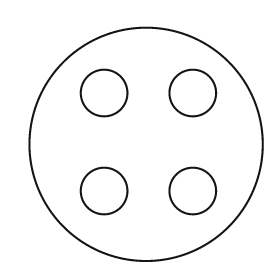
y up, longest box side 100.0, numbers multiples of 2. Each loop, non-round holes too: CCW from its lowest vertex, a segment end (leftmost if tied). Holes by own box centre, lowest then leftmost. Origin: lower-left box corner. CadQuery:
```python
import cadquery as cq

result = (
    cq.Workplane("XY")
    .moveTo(50.0, 50.0)
    .circle(50.0)
    .moveTo(32.0, 30.0)
    .circle(10.0)
    .moveTo(70.0, 30.0)
    .circle(10.0)
    .moveTo(32.0, 72.0)
    .circle(10.0)
    .moveTo(70.0, 72.0)
    .circle(10.0)
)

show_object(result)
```